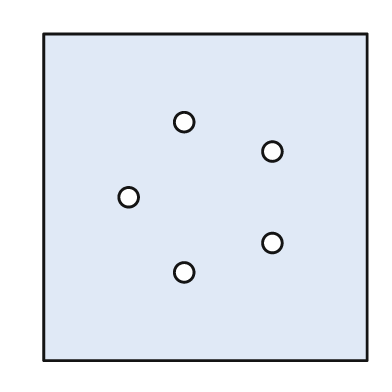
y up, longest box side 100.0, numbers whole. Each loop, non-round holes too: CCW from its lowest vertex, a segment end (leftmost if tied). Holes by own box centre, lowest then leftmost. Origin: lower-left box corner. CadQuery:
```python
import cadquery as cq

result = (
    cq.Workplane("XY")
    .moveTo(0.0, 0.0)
    .lineTo(99.0, 0.0)
    .lineTo(99.0, 100.0)
    .lineTo(0.0, 100.0)
    .close()
    .moveTo(43.0, 27.0)
    .circle(3.0)
    .moveTo(70.0, 36.0)
    .circle(3.0)
    .moveTo(26.0, 50.0)
    .circle(3.0)
    .moveTo(70.0, 64.0)
    .circle(3.0)
    .moveTo(43.0, 73.0)
    .circle(3.0)
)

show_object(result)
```